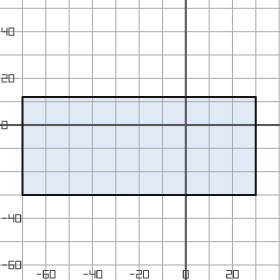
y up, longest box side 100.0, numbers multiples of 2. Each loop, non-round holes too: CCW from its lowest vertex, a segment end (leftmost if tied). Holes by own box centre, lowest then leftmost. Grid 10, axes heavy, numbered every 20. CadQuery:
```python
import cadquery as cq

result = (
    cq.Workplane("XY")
    .moveTo(-70.0, -30.0)
    .lineTo(30.0, -30.0)
    .lineTo(30.0, 12.0)
    .lineTo(-70.0, 12.0)
    .close()
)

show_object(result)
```